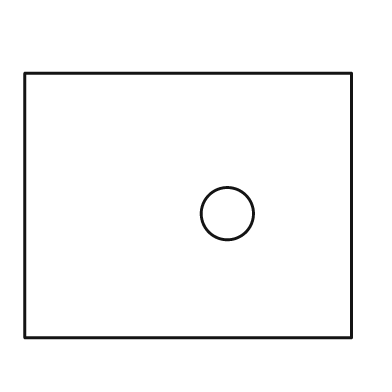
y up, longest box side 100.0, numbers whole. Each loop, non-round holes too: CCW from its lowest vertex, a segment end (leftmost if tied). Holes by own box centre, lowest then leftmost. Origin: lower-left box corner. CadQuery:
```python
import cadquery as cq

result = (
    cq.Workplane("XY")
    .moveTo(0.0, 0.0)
    .lineTo(100.0, 0.0)
    .lineTo(100.0, 81.0)
    .lineTo(0.0, 81.0)
    .close()
    .moveTo(62.0, 38.0)
    .circle(8.0)
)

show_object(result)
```